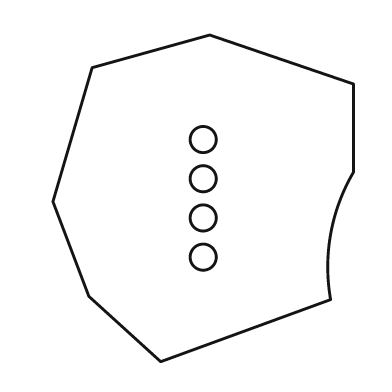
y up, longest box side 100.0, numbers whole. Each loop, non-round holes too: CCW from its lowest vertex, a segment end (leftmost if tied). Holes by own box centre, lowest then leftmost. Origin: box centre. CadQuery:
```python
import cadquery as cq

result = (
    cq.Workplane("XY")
    .moveTo(-13.0, -50.0)
    .lineTo(39.0, -31.0)
    .threePointArc((39.0, -11.0), (46.0, 8.0))
    .lineTo(46.0, 35.0)
    .lineTo(2.0, 50.0)
    .lineTo(-34.0, 40.0)
    .lineTo(-46.0, -1.0)
    .lineTo(-35.0, -30.0)
    .close()
    .moveTo(0.0, -18.0)
    .circle(4.0)
    .moveTo(0.0, -6.0)
    .circle(4.0)
    .moveTo(0.0, 6.0)
    .circle(4.0)
    .moveTo(0.0, 18.0)
    .circle(4.0)
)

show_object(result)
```